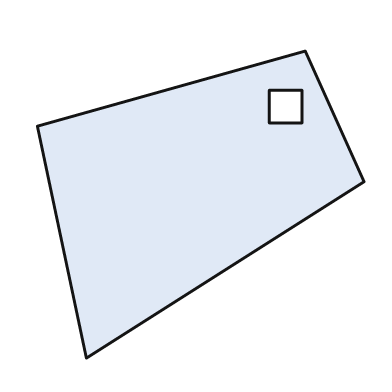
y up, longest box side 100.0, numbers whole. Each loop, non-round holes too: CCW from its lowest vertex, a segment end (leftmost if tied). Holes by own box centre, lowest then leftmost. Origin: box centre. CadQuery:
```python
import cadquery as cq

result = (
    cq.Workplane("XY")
    .moveTo(-35.0, -47.0)
    .lineTo(50.0, 7.0)
    .lineTo(32.0, 47.0)
    .lineTo(-50.0, 24.0)
    .close()
    .moveTo(21.0, 25.0)
    .lineTo(31.0, 25.0)
    .lineTo(31.0, 35.0)
    .lineTo(21.0, 35.0)
    .close()
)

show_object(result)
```